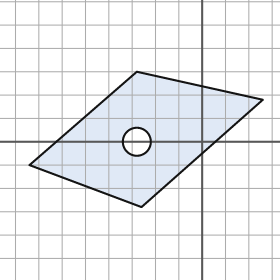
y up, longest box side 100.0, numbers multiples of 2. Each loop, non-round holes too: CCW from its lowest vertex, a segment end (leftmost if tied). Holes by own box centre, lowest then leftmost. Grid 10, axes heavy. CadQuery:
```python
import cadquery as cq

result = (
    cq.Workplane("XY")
    .moveTo(-26.0, -28.0)
    .lineTo(26.0, 18.0)
    .lineTo(-28.0, 30.0)
    .lineTo(-74.0, -10.0)
    .close()
    .moveTo(-28.0, 0.0)
    .circle(6.0)
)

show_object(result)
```